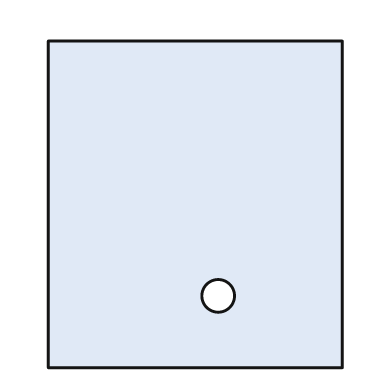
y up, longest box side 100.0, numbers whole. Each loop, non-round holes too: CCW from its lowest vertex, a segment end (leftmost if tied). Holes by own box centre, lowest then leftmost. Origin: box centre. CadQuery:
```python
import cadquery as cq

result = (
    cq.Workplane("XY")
    .moveTo(-45.0, -50.0)
    .lineTo(45.0, -50.0)
    .lineTo(45.0, 50.0)
    .lineTo(-45.0, 50.0)
    .close()
    .moveTo(7.0, -28.0)
    .circle(5.0)
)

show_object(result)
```